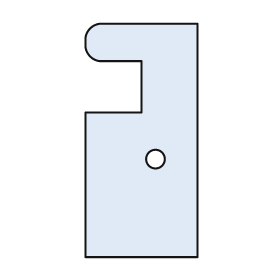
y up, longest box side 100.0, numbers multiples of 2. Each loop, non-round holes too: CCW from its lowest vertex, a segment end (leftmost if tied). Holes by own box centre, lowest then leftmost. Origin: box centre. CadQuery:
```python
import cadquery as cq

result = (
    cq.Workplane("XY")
    .moveTo(-24.0, -50.0)
    .lineTo(24.0, -50.0)
    .lineTo(24.0, 50.0)
    .lineTo(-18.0, 50.0)
    .threePointArc((-22.0, 48.0), (-24.0, 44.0))
    .lineTo(-24.0, 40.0)
    .threePointArc((-22.0, 36.0), (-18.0, 34.0))
    .lineTo(0.0, 34.0)
    .lineTo(0.0, 12.0)
    .lineTo(-24.0, 12.0)
    .close()
    .moveTo(6.0, -8.0)
    .circle(4.0)
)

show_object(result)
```